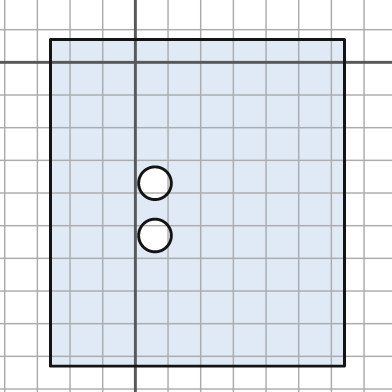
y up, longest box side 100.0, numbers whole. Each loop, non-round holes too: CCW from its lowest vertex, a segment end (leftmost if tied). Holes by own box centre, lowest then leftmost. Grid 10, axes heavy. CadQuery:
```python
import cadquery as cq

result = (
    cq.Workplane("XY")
    .moveTo(-26.0, -93.0)
    .lineTo(64.0, -93.0)
    .lineTo(64.0, 7.0)
    .lineTo(-26.0, 7.0)
    .close()
    .moveTo(6.0, -53.0)
    .circle(5.0)
    .moveTo(6.0, -37.0)
    .circle(5.0)
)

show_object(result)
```